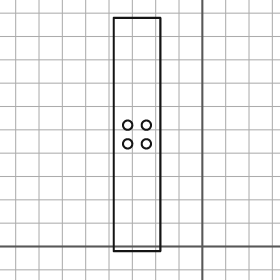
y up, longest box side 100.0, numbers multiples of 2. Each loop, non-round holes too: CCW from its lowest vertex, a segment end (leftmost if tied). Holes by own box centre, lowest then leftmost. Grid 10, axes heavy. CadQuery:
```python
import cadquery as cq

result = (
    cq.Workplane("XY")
    .moveTo(-38.0, -2.0)
    .lineTo(-18.0, -2.0)
    .lineTo(-18.0, 98.0)
    .lineTo(-38.0, 98.0)
    .close()
    .moveTo(-32.0, 44.0)
    .circle(2.0)
    .moveTo(-24.0, 44.0)
    .circle(2.0)
    .moveTo(-32.0, 52.0)
    .circle(2.0)
    .moveTo(-24.0, 52.0)
    .circle(2.0)
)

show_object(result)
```